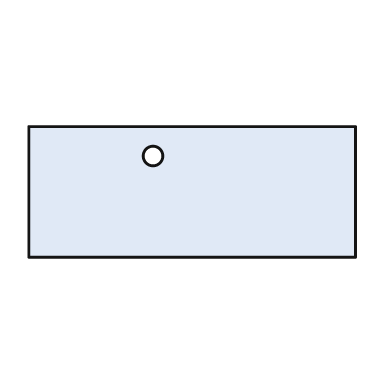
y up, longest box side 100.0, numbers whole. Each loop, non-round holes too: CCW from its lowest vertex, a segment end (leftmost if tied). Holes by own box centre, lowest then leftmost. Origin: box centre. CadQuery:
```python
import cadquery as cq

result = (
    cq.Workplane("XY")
    .moveTo(-50.0, -20.0)
    .lineTo(50.0, -20.0)
    .lineTo(50.0, 20.0)
    .lineTo(-50.0, 20.0)
    .close()
    .moveTo(-12.0, 11.0)
    .circle(3.0)
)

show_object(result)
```